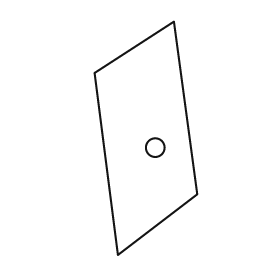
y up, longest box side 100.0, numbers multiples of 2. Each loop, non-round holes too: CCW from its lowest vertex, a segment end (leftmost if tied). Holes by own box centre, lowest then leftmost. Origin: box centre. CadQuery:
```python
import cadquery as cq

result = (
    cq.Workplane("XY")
    .moveTo(-12.0, -50.0)
    .lineTo(22.0, -24.0)
    .lineTo(12.0, 50.0)
    .lineTo(-22.0, 28.0)
    .close()
    .moveTo(4.0, -4.0)
    .circle(4.0)
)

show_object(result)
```